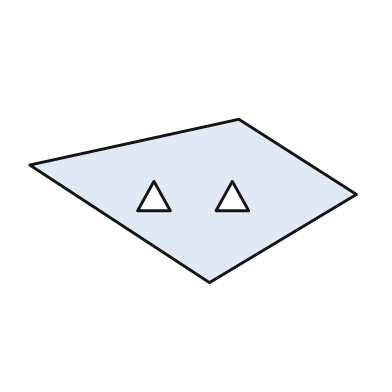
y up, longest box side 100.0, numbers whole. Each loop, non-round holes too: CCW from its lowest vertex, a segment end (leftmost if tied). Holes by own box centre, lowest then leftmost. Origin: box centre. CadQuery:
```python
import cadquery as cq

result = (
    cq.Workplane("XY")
    .moveTo(5.0, -25.0)
    .lineTo(50.0, 2.0)
    .lineTo(14.0, 25.0)
    .lineTo(-50.0, 11.0)
    .close()
    .moveTo(-17.0, -3.0)
    .lineTo(-7.0, -3.0)
    .lineTo(-12.0, 6.0)
    .close()
    .moveTo(7.0, -3.0)
    .lineTo(17.0, -3.0)
    .lineTo(12.0, 6.0)
    .close()
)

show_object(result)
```